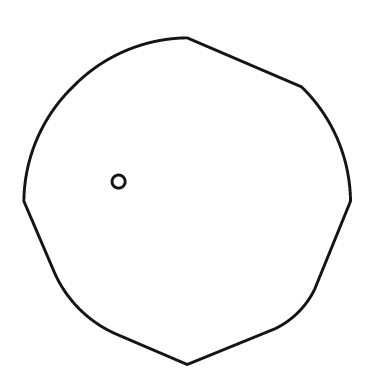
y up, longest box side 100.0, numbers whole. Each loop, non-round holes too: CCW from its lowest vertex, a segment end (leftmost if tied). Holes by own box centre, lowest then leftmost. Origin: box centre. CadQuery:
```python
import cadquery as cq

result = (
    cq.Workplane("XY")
    .moveTo(0.0, -50.0)
    .lineTo(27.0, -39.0)
    .threePointArc((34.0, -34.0), (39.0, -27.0))
    .lineTo(50.0, 0.0)
    .threePointArc((46.0, 19.0), (35.0, 35.0))
    .lineTo(0.0, 50.0)
    .threePointArc((-19.0, 46.0), (-35.0, 35.0))
    .threePointArc((-46.0, 19.0), (-50.0, 0.0))
    .lineTo(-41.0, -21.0)
    .threePointArc((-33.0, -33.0), (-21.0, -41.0))
    .close()
    .moveTo(-21.0, 6.0)
    .circle(2.0)
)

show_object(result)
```